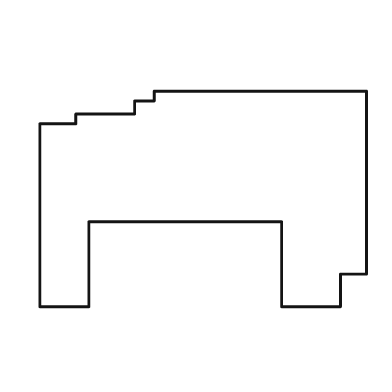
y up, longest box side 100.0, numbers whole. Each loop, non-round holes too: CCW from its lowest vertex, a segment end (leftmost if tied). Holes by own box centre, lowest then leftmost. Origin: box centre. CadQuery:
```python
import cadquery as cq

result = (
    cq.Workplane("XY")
    .moveTo(-50.0, -33.0)
    .lineTo(-35.0, -33.0)
    .lineTo(-35.0, -7.0)
    .lineTo(24.0, -7.0)
    .lineTo(24.0, -33.0)
    .lineTo(42.0, -33.0)
    .lineTo(42.0, -23.0)
    .lineTo(50.0, -23.0)
    .lineTo(50.0, 33.0)
    .lineTo(-15.0, 33.0)
    .lineTo(-15.0, 30.0)
    .lineTo(-21.0, 30.0)
    .lineTo(-21.0, 26.0)
    .lineTo(-39.0, 26.0)
    .lineTo(-39.0, 23.0)
    .lineTo(-50.0, 23.0)
    .close()
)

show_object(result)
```